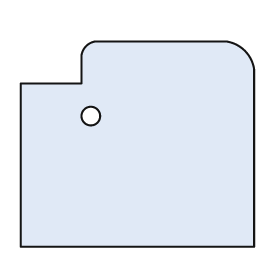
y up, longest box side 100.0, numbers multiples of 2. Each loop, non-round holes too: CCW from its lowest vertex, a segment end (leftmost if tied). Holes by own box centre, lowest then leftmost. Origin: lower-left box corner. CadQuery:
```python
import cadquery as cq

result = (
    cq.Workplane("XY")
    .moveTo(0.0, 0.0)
    .lineTo(100.0, 0.0)
    .lineTo(100.0, 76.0)
    .threePointArc((96.0, 84.0), (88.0, 88.0))
    .lineTo(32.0, 88.0)
    .threePointArc((28.0, 86.0), (26.0, 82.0))
    .lineTo(26.0, 70.0)
    .lineTo(0.0, 70.0)
    .close()
    .moveTo(30.0, 56.0)
    .circle(4.0)
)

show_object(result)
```